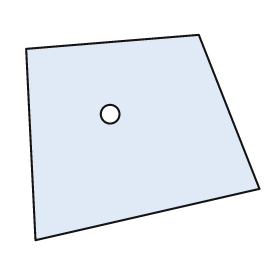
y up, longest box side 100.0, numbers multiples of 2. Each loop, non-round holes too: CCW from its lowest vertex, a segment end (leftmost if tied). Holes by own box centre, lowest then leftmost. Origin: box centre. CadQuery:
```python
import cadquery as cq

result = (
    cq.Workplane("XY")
    .moveTo(-46.0, -44.0)
    .lineTo(50.0, -22.0)
    .lineTo(24.0, 44.0)
    .lineTo(-50.0, 38.0)
    .close()
    .moveTo(-14.0, 10.0)
    .circle(4.0)
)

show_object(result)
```